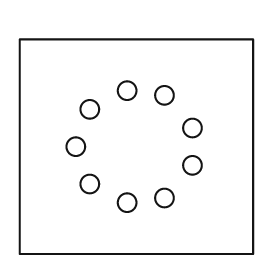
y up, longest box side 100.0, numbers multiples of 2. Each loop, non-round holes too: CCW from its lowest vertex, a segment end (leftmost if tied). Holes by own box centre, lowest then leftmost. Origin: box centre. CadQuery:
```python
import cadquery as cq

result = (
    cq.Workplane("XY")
    .moveTo(-50.0, -46.0)
    .lineTo(50.0, -46.0)
    .lineTo(50.0, 46.0)
    .lineTo(-50.0, 46.0)
    .close()
    .moveTo(-4.0, -24.0)
    .circle(4.0)
    .moveTo(12.0, -22.0)
    .circle(4.0)
    .moveTo(-20.0, -16.0)
    .circle(4.0)
    .moveTo(24.0, -8.0)
    .circle(4.0)
    .moveTo(-26.0, 0.0)
    .circle(4.0)
    .moveTo(24.0, 8.0)
    .circle(4.0)
    .moveTo(-20.0, 16.0)
    .circle(4.0)
    .moveTo(12.0, 22.0)
    .circle(4.0)
    .moveTo(-4.0, 24.0)
    .circle(4.0)
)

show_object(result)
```